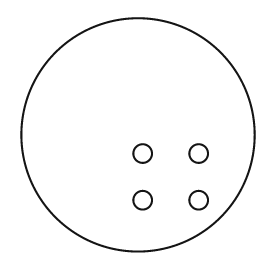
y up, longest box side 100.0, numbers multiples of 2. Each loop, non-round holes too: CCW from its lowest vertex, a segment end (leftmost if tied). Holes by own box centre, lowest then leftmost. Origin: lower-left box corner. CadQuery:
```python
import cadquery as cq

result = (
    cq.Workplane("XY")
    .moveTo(50.0, 50.0)
    .circle(50.0)
    .moveTo(52.0, 22.0)
    .circle(4.0)
    .moveTo(76.0, 22.0)
    .circle(4.0)
    .moveTo(52.0, 42.0)
    .circle(4.0)
    .moveTo(76.0, 42.0)
    .circle(4.0)
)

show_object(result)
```